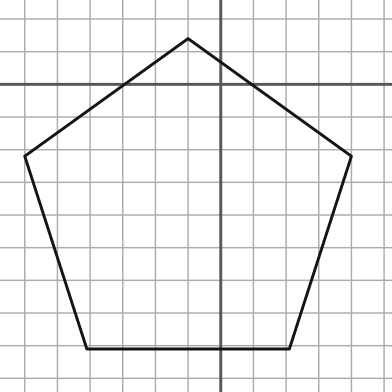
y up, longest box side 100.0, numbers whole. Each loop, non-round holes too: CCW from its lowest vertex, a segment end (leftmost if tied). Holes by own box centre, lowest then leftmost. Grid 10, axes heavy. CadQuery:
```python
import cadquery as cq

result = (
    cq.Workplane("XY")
    .moveTo(-41.0, -81.0)
    .lineTo(21.0, -81.0)
    .lineTo(40.0, -22.0)
    .lineTo(-10.0, 14.0)
    .lineTo(-60.0, -22.0)
    .close()
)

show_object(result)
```